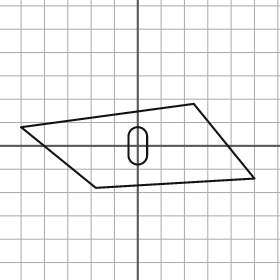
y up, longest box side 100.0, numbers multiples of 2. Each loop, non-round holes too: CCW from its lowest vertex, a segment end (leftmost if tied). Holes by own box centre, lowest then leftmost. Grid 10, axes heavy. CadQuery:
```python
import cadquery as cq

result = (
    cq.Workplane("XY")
    .moveTo(-18.0, -18.0)
    .lineTo(50.0, -14.0)
    .lineTo(24.0, 18.0)
    .lineTo(-50.0, 8.0)
    .close()
    .moveTo(-4.0, -4.0)
    .threePointArc((0.0, -8.0), (4.0, -4.0))
    .lineTo(4.0, 4.0)
    .threePointArc((0.0, 8.0), (-4.0, 4.0))
    .close()
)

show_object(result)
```